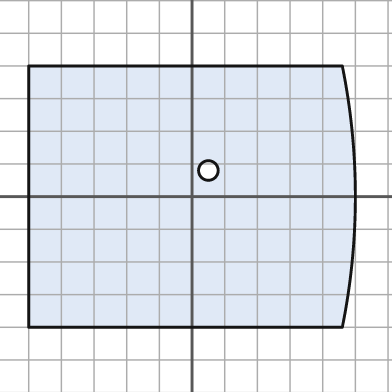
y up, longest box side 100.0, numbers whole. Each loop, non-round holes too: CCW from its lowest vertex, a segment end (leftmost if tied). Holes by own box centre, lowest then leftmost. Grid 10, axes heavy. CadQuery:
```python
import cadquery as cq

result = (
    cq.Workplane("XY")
    .moveTo(-50.0, -40.0)
    .lineTo(46.0, -40.0)
    .threePointArc((50.0, 0.0), (46.0, 40.0))
    .lineTo(-50.0, 40.0)
    .close()
    .moveTo(5.0, 8.0)
    .circle(3.0)
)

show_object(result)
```